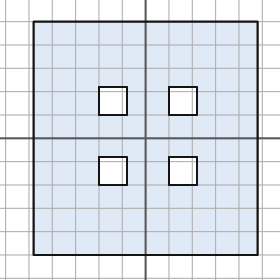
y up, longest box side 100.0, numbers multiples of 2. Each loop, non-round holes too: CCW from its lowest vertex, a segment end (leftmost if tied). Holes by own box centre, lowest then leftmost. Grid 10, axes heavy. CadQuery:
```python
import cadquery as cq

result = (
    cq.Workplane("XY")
    .moveTo(-48.0, -50.0)
    .lineTo(48.0, -50.0)
    .lineTo(48.0, 50.0)
    .lineTo(-48.0, 50.0)
    .close()
    .moveTo(-20.0, -20.0)
    .lineTo(-8.0, -20.0)
    .lineTo(-8.0, -8.0)
    .lineTo(-20.0, -8.0)
    .close()
    .moveTo(10.0, -20.0)
    .lineTo(22.0, -20.0)
    .lineTo(22.0, -8.0)
    .lineTo(10.0, -8.0)
    .close()
    .moveTo(-20.0, 10.0)
    .lineTo(-8.0, 10.0)
    .lineTo(-8.0, 22.0)
    .lineTo(-20.0, 22.0)
    .close()
    .moveTo(10.0, 10.0)
    .lineTo(22.0, 10.0)
    .lineTo(22.0, 22.0)
    .lineTo(10.0, 22.0)
    .close()
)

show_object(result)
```